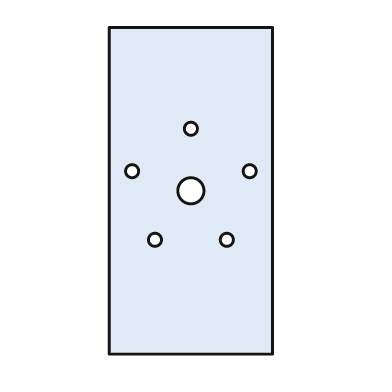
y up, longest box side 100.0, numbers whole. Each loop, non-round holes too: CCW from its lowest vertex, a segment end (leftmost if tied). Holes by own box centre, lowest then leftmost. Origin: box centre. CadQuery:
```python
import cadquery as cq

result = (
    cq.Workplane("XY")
    .moveTo(-25.0, -50.0)
    .lineTo(25.0, -50.0)
    .lineTo(25.0, 50.0)
    .lineTo(-25.0, 50.0)
    .close()
    .moveTo(-11.0, -15.0)
    .circle(2.0)
    .moveTo(11.0, -15.0)
    .circle(2.0)
    .moveTo(0.0, 0.0)
    .circle(4.0)
    .moveTo(-18.0, 6.0)
    .circle(2.0)
    .moveTo(18.0, 6.0)
    .circle(2.0)
    .moveTo(0.0, 19.0)
    .circle(2.0)
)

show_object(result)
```